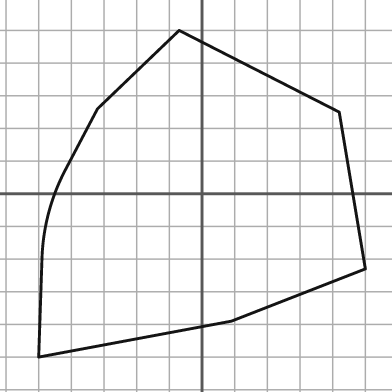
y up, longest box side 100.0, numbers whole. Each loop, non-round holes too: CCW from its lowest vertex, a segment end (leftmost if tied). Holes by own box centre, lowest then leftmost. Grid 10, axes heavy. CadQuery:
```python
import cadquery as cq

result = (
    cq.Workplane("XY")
    .moveTo(-50.0, -50.0)
    .lineTo(9.0, -39.0)
    .lineTo(50.0, -23.0)
    .lineTo(42.0, 25.0)
    .lineTo(-7.0, 50.0)
    .lineTo(-32.0, 26.0)
    .lineTo(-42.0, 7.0)
    .threePointArc((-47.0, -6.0), (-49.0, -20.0))
    .close()
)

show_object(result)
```